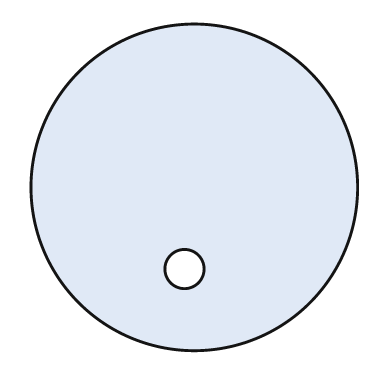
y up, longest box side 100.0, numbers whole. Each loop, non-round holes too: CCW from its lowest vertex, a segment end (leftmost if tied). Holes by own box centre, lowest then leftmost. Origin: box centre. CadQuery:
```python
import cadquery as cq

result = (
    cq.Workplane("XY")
    .moveTo(0.0, 0.0)
    .circle(50.0)
    .moveTo(-3.0, -25.0)
    .circle(6.0)
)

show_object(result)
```